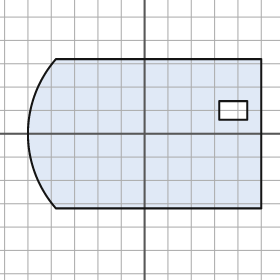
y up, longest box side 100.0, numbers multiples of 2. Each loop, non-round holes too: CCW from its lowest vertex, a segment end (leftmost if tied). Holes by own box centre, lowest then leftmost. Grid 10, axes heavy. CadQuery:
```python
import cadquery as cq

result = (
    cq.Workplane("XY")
    .moveTo(-38.0, -32.0)
    .lineTo(50.0, -32.0)
    .lineTo(50.0, 32.0)
    .lineTo(-38.0, 32.0)
    .threePointArc((-50.0, 0.0), (-38.0, -32.0))
    .close()
    .moveTo(32.0, 6.0)
    .lineTo(44.0, 6.0)
    .lineTo(44.0, 14.0)
    .lineTo(32.0, 14.0)
    .close()
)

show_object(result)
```